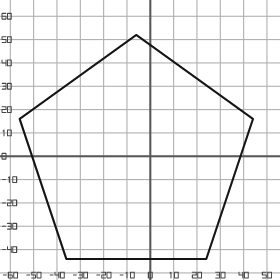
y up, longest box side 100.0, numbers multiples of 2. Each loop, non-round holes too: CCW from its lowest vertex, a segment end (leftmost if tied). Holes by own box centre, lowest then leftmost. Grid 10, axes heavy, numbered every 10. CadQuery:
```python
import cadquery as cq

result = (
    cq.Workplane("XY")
    .moveTo(-36.0, -44.0)
    .lineTo(24.0, -44.0)
    .lineTo(44.0, 16.0)
    .lineTo(-6.0, 52.0)
    .lineTo(-56.0, 16.0)
    .close()
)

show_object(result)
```